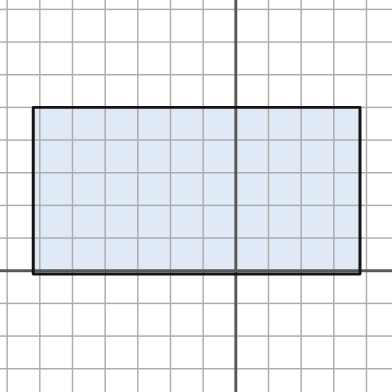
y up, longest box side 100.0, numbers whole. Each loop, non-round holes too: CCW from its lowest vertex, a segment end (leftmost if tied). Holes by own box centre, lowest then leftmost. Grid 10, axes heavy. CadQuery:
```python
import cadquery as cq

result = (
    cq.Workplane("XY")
    .moveTo(-62.0, -1.0)
    .lineTo(38.0, -1.0)
    .lineTo(38.0, 50.0)
    .lineTo(-62.0, 50.0)
    .close()
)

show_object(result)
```